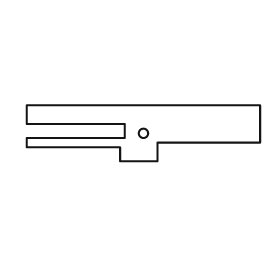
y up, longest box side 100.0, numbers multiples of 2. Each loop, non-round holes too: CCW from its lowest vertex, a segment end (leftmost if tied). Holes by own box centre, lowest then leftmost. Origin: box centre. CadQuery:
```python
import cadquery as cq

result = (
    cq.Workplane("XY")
    .moveTo(-10.0, -12.0)
    .lineTo(6.0, -12.0)
    .lineTo(6.0, -4.0)
    .lineTo(50.0, -4.0)
    .lineTo(50.0, 12.0)
    .lineTo(-50.0, 12.0)
    .lineTo(-50.0, 4.0)
    .lineTo(-8.0, 4.0)
    .lineTo(-8.0, -2.0)
    .lineTo(-50.0, -2.0)
    .lineTo(-50.0, -6.0)
    .lineTo(-10.0, -6.0)
    .close()
    .moveTo(0.0, 0.0)
    .circle(2.0)
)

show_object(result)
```